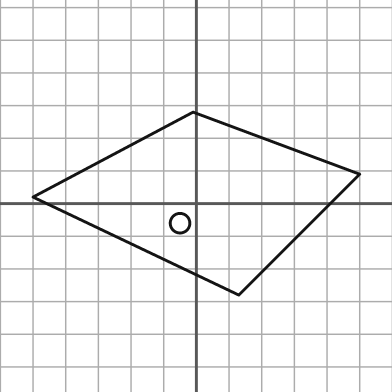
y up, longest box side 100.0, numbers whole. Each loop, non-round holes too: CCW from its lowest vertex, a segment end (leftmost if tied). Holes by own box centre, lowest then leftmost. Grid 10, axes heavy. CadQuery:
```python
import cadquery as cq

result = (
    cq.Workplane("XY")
    .moveTo(13.0, -28.0)
    .lineTo(50.0, 9.0)
    .lineTo(-1.0, 28.0)
    .lineTo(-50.0, 2.0)
    .close()
    .moveTo(-5.0, -6.0)
    .circle(3.0)
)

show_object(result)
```